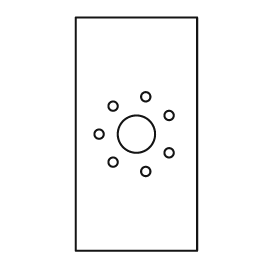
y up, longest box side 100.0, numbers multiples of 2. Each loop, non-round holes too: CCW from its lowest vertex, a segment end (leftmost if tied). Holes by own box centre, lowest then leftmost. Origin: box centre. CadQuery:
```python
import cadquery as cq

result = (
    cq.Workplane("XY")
    .moveTo(-26.0, -50.0)
    .lineTo(26.0, -50.0)
    .lineTo(26.0, 50.0)
    .lineTo(-26.0, 50.0)
    .close()
    .moveTo(4.0, -16.0)
    .circle(2.0)
    .moveTo(-10.0, -12.0)
    .circle(2.0)
    .moveTo(14.0, -8.0)
    .circle(2.0)
    .moveTo(-16.0, 0.0)
    .circle(2.0)
    .moveTo(0.0, 0.0)
    .circle(8.0)
    .moveTo(14.0, 8.0)
    .circle(2.0)
    .moveTo(-10.0, 12.0)
    .circle(2.0)
    .moveTo(4.0, 16.0)
    .circle(2.0)
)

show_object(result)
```